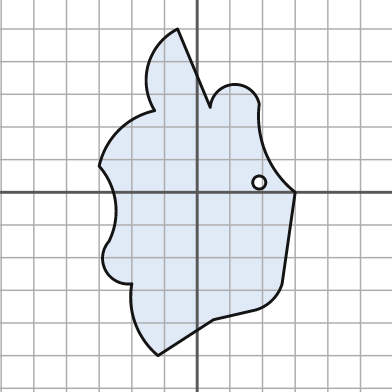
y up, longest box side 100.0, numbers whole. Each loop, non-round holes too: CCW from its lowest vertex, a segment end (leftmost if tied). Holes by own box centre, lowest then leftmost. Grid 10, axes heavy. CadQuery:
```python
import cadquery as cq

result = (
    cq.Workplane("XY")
    .moveTo(-12.0, -50.0)
    .lineTo(5.0, -39.0)
    .lineTo(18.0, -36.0)
    .threePointArc((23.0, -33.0), (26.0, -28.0))
    .lineTo(30.0, 0.0)
    .threePointArc((21.0, 12.0), (19.0, 27.0))
    .threePointArc((11.0, 33.0), (4.0, 26.0))
    .lineTo(-6.0, 50.0)
    .threePointArc((-15.0, 39.0), (-13.0, 25.0))
    .threePointArc((-24.0, 19.0), (-30.0, 8.0))
    .threePointArc((-25.0, -3.0), (-27.0, -15.0))
    .threePointArc((-28.0, -24.0), (-20.0, -28.0))
    .threePointArc((-19.0, -40.0), (-12.0, -50.0))
    .close()
    .moveTo(19.0, 3.0)
    .circle(2.0)
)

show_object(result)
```